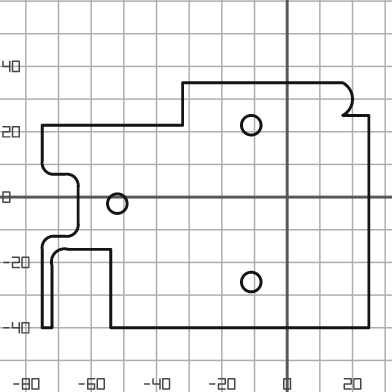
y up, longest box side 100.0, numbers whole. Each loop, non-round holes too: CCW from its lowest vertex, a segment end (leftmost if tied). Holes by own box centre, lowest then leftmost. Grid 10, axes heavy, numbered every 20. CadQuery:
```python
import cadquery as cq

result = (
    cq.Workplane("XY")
    .moveTo(-75.0, -40.0)
    .lineTo(-72.0, -40.0)
    .lineTo(-72.0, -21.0)
    .threePointArc((-71.0, -17.0), (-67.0, -16.0))
    .lineTo(-54.0, -16.0)
    .lineTo(-54.0, -40.0)
    .lineTo(25.0, -40.0)
    .lineTo(25.0, 25.0)
    .lineTo(17.0, 25.0)
    .threePointArc((20.0, 30.0), (17.0, 35.0))
    .lineTo(-32.0, 35.0)
    .lineTo(-32.0, 22.0)
    .lineTo(-75.0, 22.0)
    .lineTo(-75.0, 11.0)
    .threePointArc((-74.0, 8.0), (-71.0, 7.0))
    .lineTo(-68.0, 7.0)
    .threePointArc((-65.0, 6.0), (-64.0, 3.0))
    .lineTo(-64.0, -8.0)
    .threePointArc((-65.0, -11.0), (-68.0, -12.0))
    .lineTo(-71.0, -12.0)
    .threePointArc((-74.0, -13.0), (-75.0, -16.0))
    .close()
    .moveTo(-11.0, -26.0)
    .circle(3.0)
    .moveTo(-52.0, -2.0)
    .circle(3.0)
    .moveTo(-11.0, 22.0)
    .circle(3.0)
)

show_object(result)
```